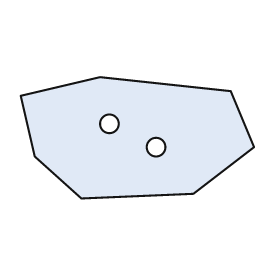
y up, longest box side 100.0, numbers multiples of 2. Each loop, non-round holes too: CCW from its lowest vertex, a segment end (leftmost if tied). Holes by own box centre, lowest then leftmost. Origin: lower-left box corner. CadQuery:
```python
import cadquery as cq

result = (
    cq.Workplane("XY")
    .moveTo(26.0, 0.0)
    .lineTo(74.0, 2.0)
    .lineTo(100.0, 22.0)
    .lineTo(90.0, 46.0)
    .lineTo(34.0, 52.0)
    .lineTo(0.0, 44.0)
    .lineTo(6.0, 18.0)
    .close()
    .moveTo(58.0, 22.0)
    .circle(4.0)
    .moveTo(38.0, 32.0)
    .circle(4.0)
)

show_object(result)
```